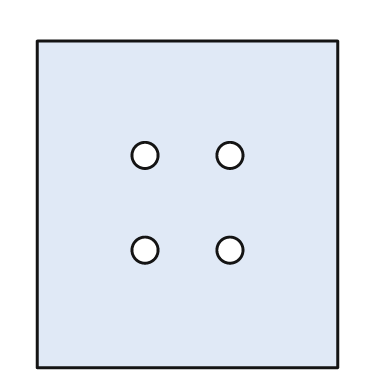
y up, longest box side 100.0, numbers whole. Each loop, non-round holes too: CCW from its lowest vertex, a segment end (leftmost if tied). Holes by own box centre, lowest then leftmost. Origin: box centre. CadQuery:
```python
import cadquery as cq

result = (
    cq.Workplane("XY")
    .moveTo(-46.0, -50.0)
    .lineTo(46.0, -50.0)
    .lineTo(46.0, 50.0)
    .lineTo(-46.0, 50.0)
    .close()
    .moveTo(-13.0, -14.0)
    .circle(4.0)
    .moveTo(13.0, -14.0)
    .circle(4.0)
    .moveTo(-13.0, 15.0)
    .circle(4.0)
    .moveTo(13.0, 15.0)
    .circle(4.0)
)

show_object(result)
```